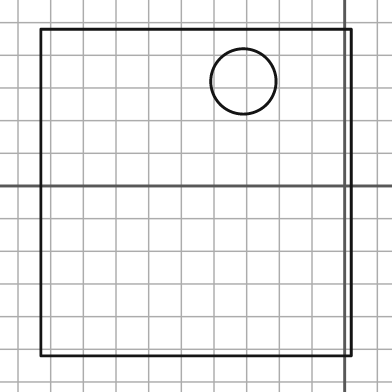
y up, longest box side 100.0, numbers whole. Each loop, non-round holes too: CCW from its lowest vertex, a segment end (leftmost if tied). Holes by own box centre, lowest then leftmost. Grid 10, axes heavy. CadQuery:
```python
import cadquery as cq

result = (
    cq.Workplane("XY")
    .moveTo(-93.0, -52.0)
    .lineTo(2.0, -52.0)
    .lineTo(2.0, 48.0)
    .lineTo(-93.0, 48.0)
    .close()
    .moveTo(-31.0, 32.0)
    .circle(10.0)
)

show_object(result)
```